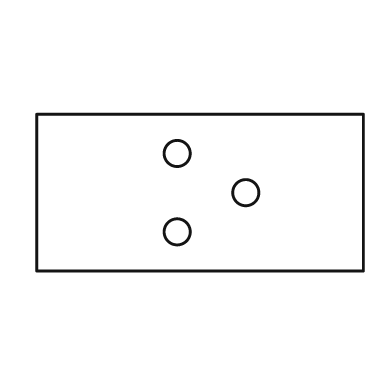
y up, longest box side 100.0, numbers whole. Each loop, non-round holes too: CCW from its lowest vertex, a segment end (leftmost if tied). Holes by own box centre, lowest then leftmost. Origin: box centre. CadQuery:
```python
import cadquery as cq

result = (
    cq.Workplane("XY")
    .moveTo(-50.0, -24.0)
    .lineTo(50.0, -24.0)
    .lineTo(50.0, 24.0)
    .lineTo(-50.0, 24.0)
    .close()
    .moveTo(-7.0, -12.0)
    .circle(4.0)
    .moveTo(14.0, 0.0)
    .circle(4.0)
    .moveTo(-7.0, 12.0)
    .circle(4.0)
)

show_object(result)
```